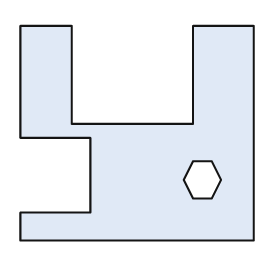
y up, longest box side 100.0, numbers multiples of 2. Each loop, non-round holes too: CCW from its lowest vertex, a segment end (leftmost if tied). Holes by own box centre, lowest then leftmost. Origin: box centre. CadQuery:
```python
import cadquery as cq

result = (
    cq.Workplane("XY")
    .moveTo(-50.0, -46.0)
    .lineTo(50.0, -46.0)
    .lineTo(50.0, 46.0)
    .lineTo(24.0, 46.0)
    .lineTo(24.0, 4.0)
    .lineTo(-28.0, 4.0)
    .lineTo(-28.0, 46.0)
    .lineTo(-50.0, 46.0)
    .lineTo(-50.0, -2.0)
    .lineTo(-20.0, -2.0)
    .lineTo(-20.0, -34.0)
    .lineTo(-50.0, -34.0)
    .close()
    .moveTo(24.0, -28.0)
    .lineTo(32.0, -28.0)
    .lineTo(36.0, -20.0)
    .lineTo(32.0, -12.0)
    .lineTo(24.0, -12.0)
    .lineTo(20.0, -20.0)
    .close()
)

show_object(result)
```